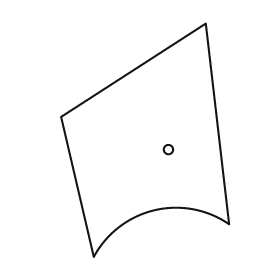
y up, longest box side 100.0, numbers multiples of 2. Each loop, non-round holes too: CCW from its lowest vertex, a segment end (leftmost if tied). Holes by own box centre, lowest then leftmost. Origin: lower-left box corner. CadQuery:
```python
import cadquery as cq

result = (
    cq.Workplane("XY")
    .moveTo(14.0, 0.0)
    .threePointArc((40.0, 20.0), (72.0, 14.0))
    .lineTo(62.0, 100.0)
    .lineTo(0.0, 60.0)
    .close()
    .moveTo(46.0, 46.0)
    .circle(2.0)
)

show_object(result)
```